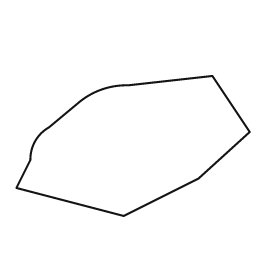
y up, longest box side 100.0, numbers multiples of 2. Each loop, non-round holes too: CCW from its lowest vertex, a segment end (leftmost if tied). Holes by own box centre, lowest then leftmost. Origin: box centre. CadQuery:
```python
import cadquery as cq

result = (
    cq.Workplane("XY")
    .moveTo(-4.0, -30.0)
    .lineTo(28.0, -14.0)
    .lineTo(50.0, 6.0)
    .lineTo(34.0, 30.0)
    .lineTo(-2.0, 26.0)
    .threePointArc((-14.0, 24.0), (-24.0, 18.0))
    .lineTo(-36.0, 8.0)
    .threePointArc((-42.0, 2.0), (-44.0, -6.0))
    .lineTo(-50.0, -18.0)
    .close()
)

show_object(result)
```